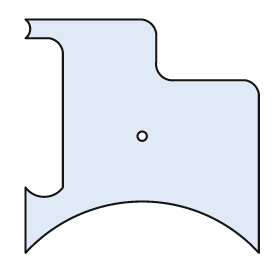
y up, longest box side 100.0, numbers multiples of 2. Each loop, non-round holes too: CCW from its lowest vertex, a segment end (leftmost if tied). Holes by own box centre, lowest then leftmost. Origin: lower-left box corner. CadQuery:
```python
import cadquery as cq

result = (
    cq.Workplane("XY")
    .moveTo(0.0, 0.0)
    .threePointArc((50.0, 22.0), (100.0, 0.0))
    .lineTo(100.0, 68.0)
    .threePointArc((98.0, 72.0), (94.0, 74.0))
    .lineTo(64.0, 74.0)
    .threePointArc((58.0, 76.0), (56.0, 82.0))
    .lineTo(56.0, 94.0)
    .threePointArc((54.0, 98.0), (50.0, 100.0))
    .lineTo(0.0, 100.0)
    .threePointArc((2.0, 96.0), (0.0, 92.0))
    .lineTo(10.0, 92.0)
    .threePointArc((14.0, 90.0), (16.0, 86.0))
    .lineTo(16.0, 28.0)
    .threePointArc((8.0, 24.0), (0.0, 28.0))
    .close()
    .moveTo(50.0, 50.0)
    .circle(2.0)
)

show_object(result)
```